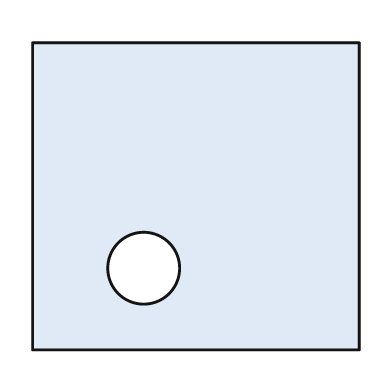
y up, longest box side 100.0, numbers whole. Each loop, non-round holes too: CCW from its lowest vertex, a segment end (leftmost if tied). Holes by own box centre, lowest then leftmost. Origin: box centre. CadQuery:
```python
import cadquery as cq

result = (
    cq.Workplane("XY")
    .moveTo(-50.0, -47.0)
    .lineTo(50.0, -47.0)
    .lineTo(50.0, 47.0)
    .lineTo(-50.0, 47.0)
    .close()
    .moveTo(-16.0, -22.0)
    .circle(11.0)
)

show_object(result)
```